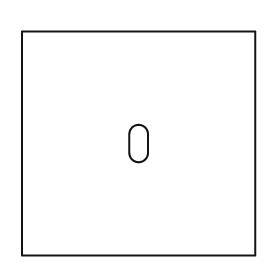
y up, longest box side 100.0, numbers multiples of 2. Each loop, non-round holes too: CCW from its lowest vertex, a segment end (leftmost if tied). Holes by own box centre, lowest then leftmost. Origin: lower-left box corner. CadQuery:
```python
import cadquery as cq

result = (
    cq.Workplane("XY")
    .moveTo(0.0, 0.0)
    .lineTo(100.0, 0.0)
    .lineTo(100.0, 96.0)
    .lineTo(0.0, 96.0)
    .close()
    .moveTo(46.0, 44.0)
    .threePointArc((50.0, 40.0), (54.0, 44.0))
    .lineTo(54.0, 52.0)
    .threePointArc((50.0, 56.0), (46.0, 52.0))
    .close()
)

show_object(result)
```